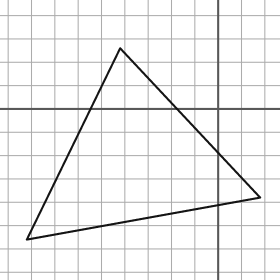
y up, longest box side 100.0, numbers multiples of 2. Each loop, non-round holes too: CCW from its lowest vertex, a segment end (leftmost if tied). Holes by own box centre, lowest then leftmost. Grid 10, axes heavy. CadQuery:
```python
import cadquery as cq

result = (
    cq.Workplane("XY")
    .moveTo(-82.0, -56.0)
    .lineTo(18.0, -38.0)
    .lineTo(-42.0, 26.0)
    .close()
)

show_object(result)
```